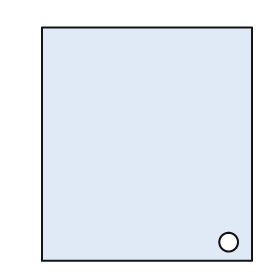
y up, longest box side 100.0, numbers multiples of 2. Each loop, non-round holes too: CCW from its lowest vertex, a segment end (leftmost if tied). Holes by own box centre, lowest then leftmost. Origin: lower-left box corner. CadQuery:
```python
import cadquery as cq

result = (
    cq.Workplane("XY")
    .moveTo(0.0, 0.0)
    .lineTo(90.0, 0.0)
    .lineTo(90.0, 100.0)
    .lineTo(0.0, 100.0)
    .close()
    .moveTo(80.0, 8.0)
    .circle(4.0)
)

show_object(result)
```